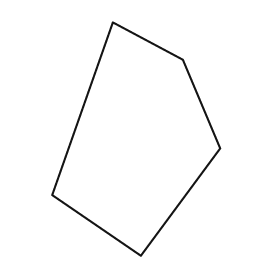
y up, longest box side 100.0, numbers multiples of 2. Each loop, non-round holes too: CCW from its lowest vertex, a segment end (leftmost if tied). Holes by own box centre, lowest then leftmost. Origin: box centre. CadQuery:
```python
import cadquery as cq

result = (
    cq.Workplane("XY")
    .moveTo(2.0, -50.0)
    .lineTo(36.0, -4.0)
    .lineTo(20.0, 34.0)
    .lineTo(-10.0, 50.0)
    .lineTo(-36.0, -24.0)
    .close()
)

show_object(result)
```